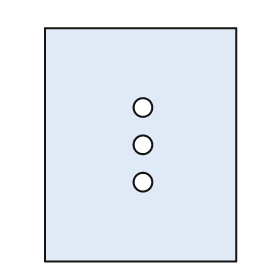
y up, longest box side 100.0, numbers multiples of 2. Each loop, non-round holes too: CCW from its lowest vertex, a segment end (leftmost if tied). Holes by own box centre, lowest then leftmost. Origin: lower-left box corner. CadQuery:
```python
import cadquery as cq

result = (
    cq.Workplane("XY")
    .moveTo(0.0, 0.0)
    .lineTo(82.0, 0.0)
    .lineTo(82.0, 100.0)
    .lineTo(0.0, 100.0)
    .close()
    .moveTo(42.0, 34.0)
    .circle(4.0)
    .moveTo(42.0, 50.0)
    .circle(4.0)
    .moveTo(42.0, 66.0)
    .circle(4.0)
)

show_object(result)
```